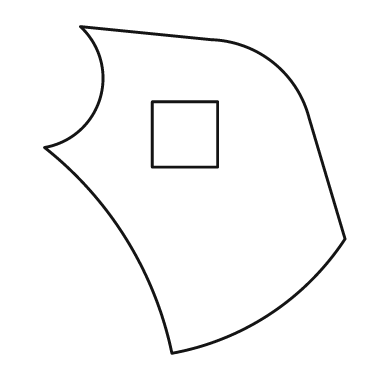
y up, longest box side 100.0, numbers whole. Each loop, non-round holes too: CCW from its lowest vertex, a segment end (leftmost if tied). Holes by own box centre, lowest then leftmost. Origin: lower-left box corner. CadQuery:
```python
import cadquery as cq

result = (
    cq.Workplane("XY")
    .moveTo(39.0, 0.0)
    .threePointArc((69.0, 12.0), (92.0, 35.0))
    .lineTo(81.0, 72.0)
    .threePointArc((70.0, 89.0), (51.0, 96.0))
    .lineTo(11.0, 100.0)
    .threePointArc((17.0, 78.0), (0.0, 63.0))
    .threePointArc((25.0, 35.0), (39.0, 0.0))
    .close()
    .moveTo(33.0, 57.0)
    .lineTo(53.0, 57.0)
    .lineTo(53.0, 77.0)
    .lineTo(33.0, 77.0)
    .close()
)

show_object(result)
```